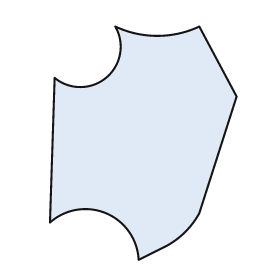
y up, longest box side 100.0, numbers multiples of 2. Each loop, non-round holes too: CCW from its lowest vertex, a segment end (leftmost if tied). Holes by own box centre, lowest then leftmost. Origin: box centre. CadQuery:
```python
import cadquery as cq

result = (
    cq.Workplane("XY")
    .moveTo(-2.0, -50.0)
    .lineTo(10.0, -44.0)
    .threePointArc((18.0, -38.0), (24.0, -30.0))
    .lineTo(40.0, 20.0)
    .lineTo(24.0, 50.0)
    .threePointArc((6.0, 46.0), (-12.0, 50.0))
    .threePointArc((-16.0, 28.0), (-38.0, 28.0))
    .lineTo(-40.0, -34.0)
    .threePointArc((-16.0, -30.0), (-2.0, -50.0))
    .close()
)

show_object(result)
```